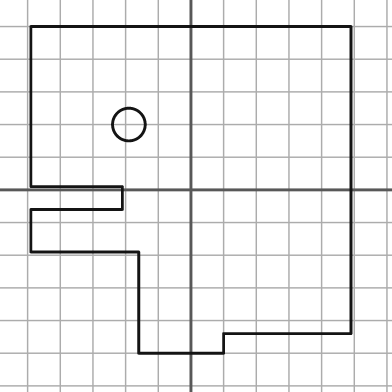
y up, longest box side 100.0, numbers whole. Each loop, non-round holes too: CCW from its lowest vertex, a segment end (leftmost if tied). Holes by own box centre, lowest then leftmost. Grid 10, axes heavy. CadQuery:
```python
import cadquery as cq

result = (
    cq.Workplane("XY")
    .moveTo(-16.0, -50.0)
    .lineTo(10.0, -50.0)
    .lineTo(10.0, -44.0)
    .lineTo(49.0, -44.0)
    .lineTo(49.0, 50.0)
    .lineTo(-49.0, 50.0)
    .lineTo(-49.0, 1.0)
    .lineTo(-21.0, 1.0)
    .lineTo(-21.0, -6.0)
    .lineTo(-49.0, -6.0)
    .lineTo(-49.0, -19.0)
    .lineTo(-16.0, -19.0)
    .close()
    .moveTo(-19.0, 20.0)
    .circle(5.0)
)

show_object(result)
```